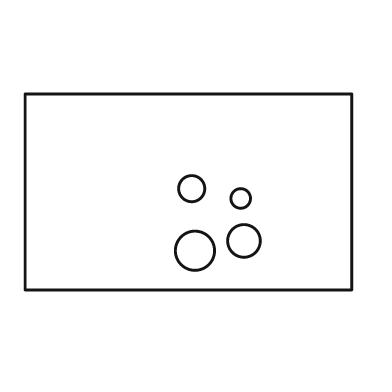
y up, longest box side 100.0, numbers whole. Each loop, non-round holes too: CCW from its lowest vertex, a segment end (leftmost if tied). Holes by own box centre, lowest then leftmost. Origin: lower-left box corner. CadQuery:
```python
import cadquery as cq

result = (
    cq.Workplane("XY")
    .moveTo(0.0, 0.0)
    .lineTo(100.0, 0.0)
    .lineTo(100.0, 60.0)
    .lineTo(0.0, 60.0)
    .close()
    .moveTo(52.0, 12.0)
    .circle(6.0)
    .moveTo(67.0, 15.0)
    .circle(5.0)
    .moveTo(66.0, 28.0)
    .circle(3.0)
    .moveTo(51.0, 31.0)
    .circle(4.0)
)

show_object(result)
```